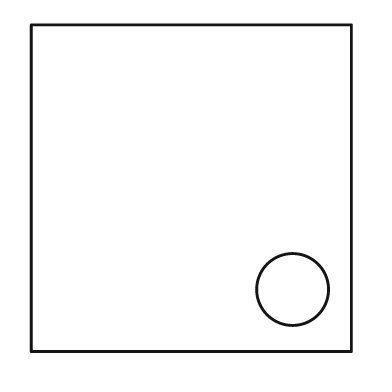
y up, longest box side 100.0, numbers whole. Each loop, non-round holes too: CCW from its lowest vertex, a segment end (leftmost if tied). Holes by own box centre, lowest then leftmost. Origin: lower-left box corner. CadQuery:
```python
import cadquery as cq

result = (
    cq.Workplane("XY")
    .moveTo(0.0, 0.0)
    .lineTo(98.0, 0.0)
    .lineTo(98.0, 100.0)
    .lineTo(0.0, 100.0)
    .close()
    .moveTo(80.0, 19.0)
    .circle(11.0)
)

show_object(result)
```